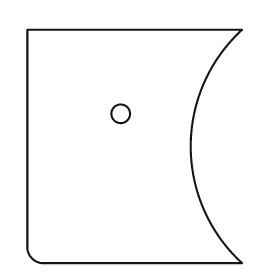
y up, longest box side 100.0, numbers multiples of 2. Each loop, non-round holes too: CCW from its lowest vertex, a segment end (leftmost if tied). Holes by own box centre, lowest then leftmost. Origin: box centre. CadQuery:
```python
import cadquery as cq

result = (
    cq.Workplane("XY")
    .moveTo(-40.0, -50.0)
    .lineTo(46.0, -50.0)
    .threePointArc((24.0, 0.0), (46.0, 50.0))
    .lineTo(-46.0, 50.0)
    .lineTo(-46.0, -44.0)
    .threePointArc((-44.0, -48.0), (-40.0, -50.0))
    .close()
    .moveTo(-6.0, 14.0)
    .circle(4.0)
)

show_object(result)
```